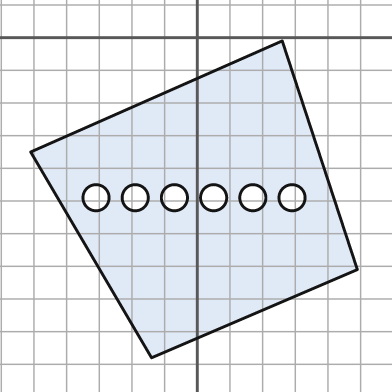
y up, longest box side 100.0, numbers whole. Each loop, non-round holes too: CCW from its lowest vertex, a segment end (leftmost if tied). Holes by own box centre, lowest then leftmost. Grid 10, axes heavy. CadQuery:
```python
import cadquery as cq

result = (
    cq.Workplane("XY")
    .moveTo(-14.0, -98.0)
    .lineTo(49.0, -71.0)
    .lineTo(26.0, -1.0)
    .lineTo(-51.0, -35.0)
    .close()
    .moveTo(-31.0, -49.0)
    .circle(4.0)
    .moveTo(-19.0, -49.0)
    .circle(4.0)
    .moveTo(-7.0, -49.0)
    .circle(4.0)
    .moveTo(5.0, -49.0)
    .circle(4.0)
    .moveTo(17.0, -49.0)
    .circle(4.0)
    .moveTo(29.0, -49.0)
    .circle(4.0)
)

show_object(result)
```